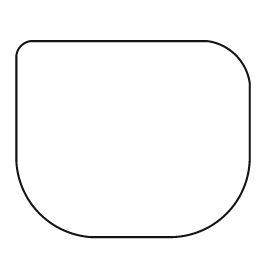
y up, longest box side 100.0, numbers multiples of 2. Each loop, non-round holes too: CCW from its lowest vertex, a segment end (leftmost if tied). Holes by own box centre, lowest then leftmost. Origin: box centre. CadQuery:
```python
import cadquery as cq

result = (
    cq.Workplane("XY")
    .moveTo(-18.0, -42.0)
    .lineTo(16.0, -42.0)
    .threePointArc((40.0, -32.0), (50.0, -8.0))
    .lineTo(50.0, 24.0)
    .threePointArc((44.0, 36.0), (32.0, 42.0))
    .lineTo(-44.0, 42.0)
    .threePointArc((-48.0, 40.0), (-50.0, 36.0))
    .lineTo(-50.0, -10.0)
    .threePointArc((-40.0, -32.0), (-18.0, -42.0))
    .close()
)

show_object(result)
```